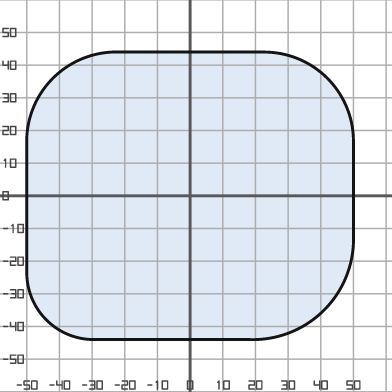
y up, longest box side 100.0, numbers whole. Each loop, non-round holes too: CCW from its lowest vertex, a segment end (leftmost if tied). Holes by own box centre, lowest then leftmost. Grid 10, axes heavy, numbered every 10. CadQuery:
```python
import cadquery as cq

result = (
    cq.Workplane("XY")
    .moveTo(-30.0, -44.0)
    .lineTo(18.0, -44.0)
    .threePointArc((41.0, -35.0), (50.0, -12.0))
    .lineTo(50.0, 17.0)
    .threePointArc((42.0, 36.0), (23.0, 44.0))
    .lineTo(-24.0, 44.0)
    .threePointArc((-42.0, 36.0), (-50.0, 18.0))
    .lineTo(-50.0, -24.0)
    .threePointArc((-44.0, -38.0), (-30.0, -44.0))
    .close()
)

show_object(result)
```